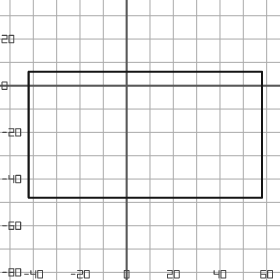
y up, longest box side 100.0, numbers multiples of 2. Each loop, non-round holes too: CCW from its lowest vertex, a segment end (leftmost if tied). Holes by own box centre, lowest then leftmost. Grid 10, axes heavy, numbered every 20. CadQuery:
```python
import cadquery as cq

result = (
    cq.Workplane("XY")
    .moveTo(-42.0, -48.0)
    .lineTo(58.0, -48.0)
    .lineTo(58.0, 6.0)
    .lineTo(-42.0, 6.0)
    .close()
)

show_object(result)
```